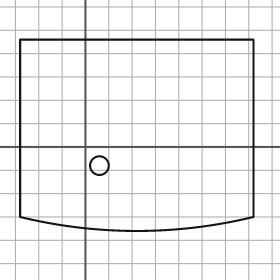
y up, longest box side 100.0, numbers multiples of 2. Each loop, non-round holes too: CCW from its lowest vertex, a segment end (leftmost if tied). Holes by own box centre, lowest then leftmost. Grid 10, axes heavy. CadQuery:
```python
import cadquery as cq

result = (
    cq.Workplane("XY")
    .moveTo(-28.0, -30.0)
    .threePointArc((22.0, -36.0), (72.0, -30.0))
    .lineTo(72.0, 46.0)
    .lineTo(-28.0, 46.0)
    .close()
    .moveTo(6.0, -8.0)
    .circle(4.0)
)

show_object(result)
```